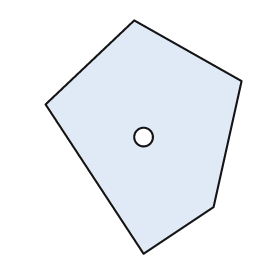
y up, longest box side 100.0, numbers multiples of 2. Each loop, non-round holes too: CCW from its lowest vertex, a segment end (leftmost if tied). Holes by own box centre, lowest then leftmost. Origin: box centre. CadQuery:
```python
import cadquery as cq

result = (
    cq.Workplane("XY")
    .moveTo(0.0, -50.0)
    .lineTo(30.0, -30.0)
    .lineTo(42.0, 24.0)
    .lineTo(-4.0, 50.0)
    .lineTo(-42.0, 14.0)
    .close()
    .moveTo(0.0, 0.0)
    .circle(4.0)
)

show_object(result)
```